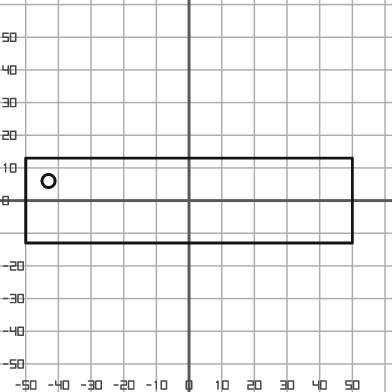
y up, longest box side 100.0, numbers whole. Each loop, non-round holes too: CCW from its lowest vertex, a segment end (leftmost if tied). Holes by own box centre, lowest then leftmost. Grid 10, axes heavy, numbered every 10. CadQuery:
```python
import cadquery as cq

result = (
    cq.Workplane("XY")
    .moveTo(-50.0, -13.0)
    .lineTo(50.0, -13.0)
    .lineTo(50.0, 13.0)
    .lineTo(-50.0, 13.0)
    .close()
    .moveTo(-43.0, 6.0)
    .circle(2.0)
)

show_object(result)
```